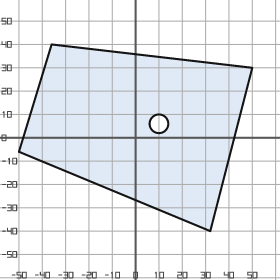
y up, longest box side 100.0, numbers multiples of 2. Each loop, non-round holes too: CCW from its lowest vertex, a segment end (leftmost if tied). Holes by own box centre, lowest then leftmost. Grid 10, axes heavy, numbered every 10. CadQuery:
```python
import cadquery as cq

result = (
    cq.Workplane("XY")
    .moveTo(32.0, -40.0)
    .lineTo(50.0, 30.0)
    .lineTo(-36.0, 40.0)
    .lineTo(-50.0, -6.0)
    .close()
    .moveTo(10.0, 6.0)
    .circle(4.0)
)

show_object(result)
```